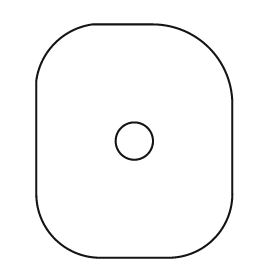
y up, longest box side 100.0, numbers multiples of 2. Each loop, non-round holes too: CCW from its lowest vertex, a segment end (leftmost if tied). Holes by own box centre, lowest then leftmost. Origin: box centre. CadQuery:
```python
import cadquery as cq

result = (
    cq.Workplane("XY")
    .moveTo(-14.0, -50.0)
    .lineTo(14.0, -50.0)
    .threePointArc((34.0, -42.0), (42.0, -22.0))
    .lineTo(42.0, 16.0)
    .threePointArc((32.0, 40.0), (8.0, 50.0))
    .lineTo(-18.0, 50.0)
    .threePointArc((-34.0, 42.0), (-42.0, 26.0))
    .lineTo(-42.0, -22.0)
    .threePointArc((-34.0, -42.0), (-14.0, -50.0))
    .close()
    .moveTo(0.0, 0.0)
    .circle(8.0)
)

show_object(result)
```